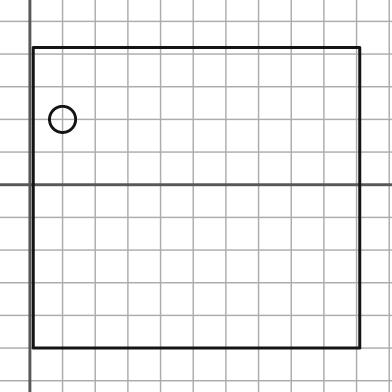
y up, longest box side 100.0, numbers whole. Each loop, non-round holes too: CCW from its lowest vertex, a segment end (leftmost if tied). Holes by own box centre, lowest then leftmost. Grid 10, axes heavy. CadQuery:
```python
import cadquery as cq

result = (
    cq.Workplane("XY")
    .moveTo(1.0, -50.0)
    .lineTo(101.0, -50.0)
    .lineTo(101.0, 42.0)
    .lineTo(1.0, 42.0)
    .close()
    .moveTo(10.0, 20.0)
    .circle(4.0)
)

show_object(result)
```